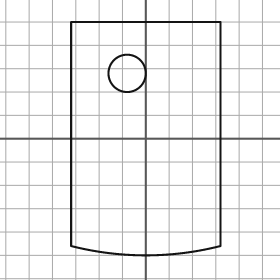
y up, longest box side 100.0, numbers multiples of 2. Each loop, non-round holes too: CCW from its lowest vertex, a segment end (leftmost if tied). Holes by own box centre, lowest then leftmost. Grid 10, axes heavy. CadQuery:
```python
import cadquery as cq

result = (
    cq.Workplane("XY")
    .moveTo(-32.0, -46.0)
    .threePointArc((0.0, -50.0), (32.0, -46.0))
    .lineTo(32.0, 50.0)
    .lineTo(-32.0, 50.0)
    .close()
    .moveTo(-8.0, 28.0)
    .circle(8.0)
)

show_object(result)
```